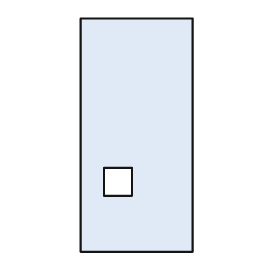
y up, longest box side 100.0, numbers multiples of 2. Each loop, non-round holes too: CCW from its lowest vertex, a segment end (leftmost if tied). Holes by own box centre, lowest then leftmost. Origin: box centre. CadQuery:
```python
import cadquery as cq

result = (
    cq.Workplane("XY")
    .moveTo(-24.0, -50.0)
    .lineTo(24.0, -50.0)
    .lineTo(24.0, 50.0)
    .lineTo(-24.0, 50.0)
    .close()
    .moveTo(-14.0, -26.0)
    .lineTo(-2.0, -26.0)
    .lineTo(-2.0, -14.0)
    .lineTo(-14.0, -14.0)
    .close()
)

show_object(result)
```